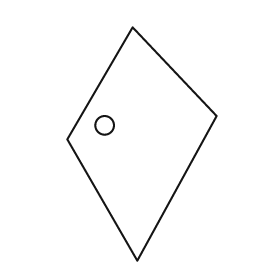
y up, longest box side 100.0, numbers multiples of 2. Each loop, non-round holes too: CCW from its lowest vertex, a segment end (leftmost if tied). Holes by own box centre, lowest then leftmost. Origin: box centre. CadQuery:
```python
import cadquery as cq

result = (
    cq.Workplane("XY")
    .moveTo(-2.0, -50.0)
    .lineTo(32.0, 12.0)
    .lineTo(-4.0, 50.0)
    .lineTo(-32.0, 2.0)
    .close()
    .moveTo(-16.0, 8.0)
    .circle(4.0)
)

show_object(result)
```